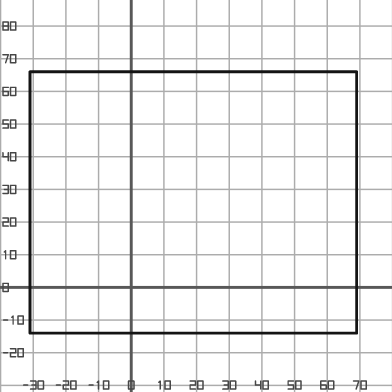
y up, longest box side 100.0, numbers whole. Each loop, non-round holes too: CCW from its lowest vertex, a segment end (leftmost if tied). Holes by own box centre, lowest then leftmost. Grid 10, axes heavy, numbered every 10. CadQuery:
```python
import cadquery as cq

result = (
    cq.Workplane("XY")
    .moveTo(-31.0, -14.0)
    .lineTo(69.0, -14.0)
    .lineTo(69.0, 66.0)
    .lineTo(-31.0, 66.0)
    .close()
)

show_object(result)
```